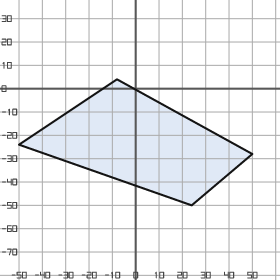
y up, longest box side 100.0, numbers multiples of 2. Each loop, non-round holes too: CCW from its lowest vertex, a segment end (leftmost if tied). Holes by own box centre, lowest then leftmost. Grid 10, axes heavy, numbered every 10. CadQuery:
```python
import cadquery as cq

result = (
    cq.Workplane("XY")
    .moveTo(24.0, -50.0)
    .lineTo(50.0, -28.0)
    .lineTo(-8.0, 4.0)
    .lineTo(-50.0, -24.0)
    .close()
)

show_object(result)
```